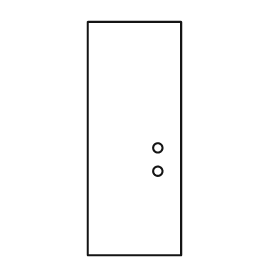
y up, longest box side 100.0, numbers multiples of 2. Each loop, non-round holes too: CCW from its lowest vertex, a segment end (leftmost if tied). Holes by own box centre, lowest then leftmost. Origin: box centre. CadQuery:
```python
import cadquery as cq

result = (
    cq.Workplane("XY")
    .moveTo(-20.0, -50.0)
    .lineTo(20.0, -50.0)
    .lineTo(20.0, 50.0)
    .lineTo(-20.0, 50.0)
    .close()
    .moveTo(10.0, -14.0)
    .circle(2.0)
    .moveTo(10.0, -4.0)
    .circle(2.0)
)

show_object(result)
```